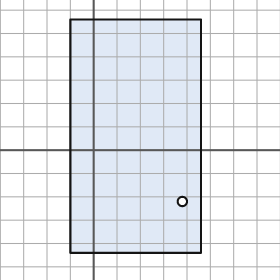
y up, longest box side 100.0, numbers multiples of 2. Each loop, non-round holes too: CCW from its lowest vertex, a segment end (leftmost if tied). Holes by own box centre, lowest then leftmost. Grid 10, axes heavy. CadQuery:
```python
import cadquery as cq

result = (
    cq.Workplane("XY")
    .moveTo(-10.0, -44.0)
    .lineTo(46.0, -44.0)
    .lineTo(46.0, 56.0)
    .lineTo(-10.0, 56.0)
    .close()
    .moveTo(38.0, -22.0)
    .circle(2.0)
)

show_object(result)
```